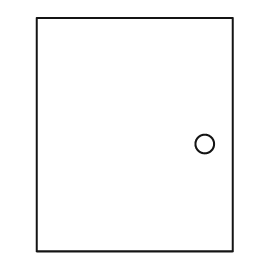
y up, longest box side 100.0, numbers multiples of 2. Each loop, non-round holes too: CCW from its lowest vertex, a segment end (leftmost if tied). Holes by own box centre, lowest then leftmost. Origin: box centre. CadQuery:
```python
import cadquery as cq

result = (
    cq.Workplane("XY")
    .moveTo(-42.0, -50.0)
    .lineTo(42.0, -50.0)
    .lineTo(42.0, 50.0)
    .lineTo(-42.0, 50.0)
    .close()
    .moveTo(30.0, -4.0)
    .circle(4.0)
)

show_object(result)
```